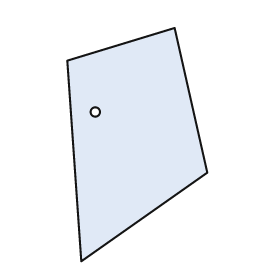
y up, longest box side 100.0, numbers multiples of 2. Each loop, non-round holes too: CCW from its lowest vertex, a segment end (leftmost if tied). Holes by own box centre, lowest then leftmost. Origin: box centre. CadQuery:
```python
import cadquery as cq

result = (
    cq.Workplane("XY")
    .moveTo(-24.0, -50.0)
    .lineTo(30.0, -12.0)
    .lineTo(16.0, 50.0)
    .lineTo(-30.0, 36.0)
    .close()
    .moveTo(-18.0, 14.0)
    .circle(2.0)
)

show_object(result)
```